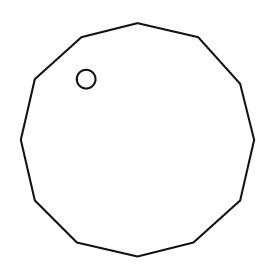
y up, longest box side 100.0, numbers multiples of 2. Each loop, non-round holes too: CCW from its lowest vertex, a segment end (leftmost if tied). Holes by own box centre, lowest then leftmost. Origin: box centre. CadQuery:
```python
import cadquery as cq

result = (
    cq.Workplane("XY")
    .moveTo(0.0, -50.0)
    .lineTo(24.0, -44.0)
    .lineTo(44.0, -26.0)
    .lineTo(50.0, 0.0)
    .lineTo(44.0, 24.0)
    .lineTo(26.0, 44.0)
    .lineTo(0.0, 50.0)
    .lineTo(-24.0, 44.0)
    .lineTo(-44.0, 26.0)
    .lineTo(-50.0, 0.0)
    .lineTo(-44.0, -26.0)
    .lineTo(-26.0, -44.0)
    .close()
    .moveTo(-22.0, 26.0)
    .circle(4.0)
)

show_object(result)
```